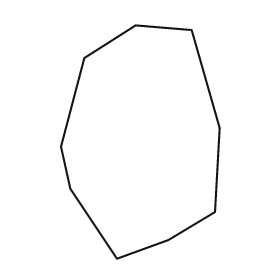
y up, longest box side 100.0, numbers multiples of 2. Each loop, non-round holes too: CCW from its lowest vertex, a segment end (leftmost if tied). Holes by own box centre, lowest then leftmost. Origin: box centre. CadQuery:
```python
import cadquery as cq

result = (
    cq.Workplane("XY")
    .moveTo(-10.0, -50.0)
    .lineTo(12.0, -42.0)
    .lineTo(32.0, -30.0)
    .lineTo(34.0, 6.0)
    .lineTo(22.0, 48.0)
    .lineTo(-2.0, 50.0)
    .lineTo(-24.0, 36.0)
    .lineTo(-34.0, -2.0)
    .lineTo(-30.0, -20.0)
    .close()
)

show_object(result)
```